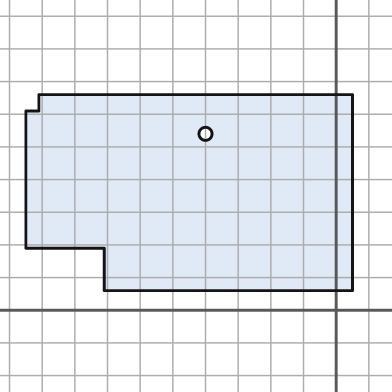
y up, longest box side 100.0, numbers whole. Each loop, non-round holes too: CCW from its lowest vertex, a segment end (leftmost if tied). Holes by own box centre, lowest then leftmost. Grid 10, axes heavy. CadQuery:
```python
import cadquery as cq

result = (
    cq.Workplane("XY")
    .moveTo(-71.0, 6.0)
    .lineTo(5.0, 6.0)
    .lineTo(5.0, 66.0)
    .lineTo(-91.0, 66.0)
    .lineTo(-91.0, 61.0)
    .lineTo(-95.0, 61.0)
    .lineTo(-95.0, 19.0)
    .lineTo(-71.0, 19.0)
    .close()
    .moveTo(-40.0, 54.0)
    .circle(2.0)
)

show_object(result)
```